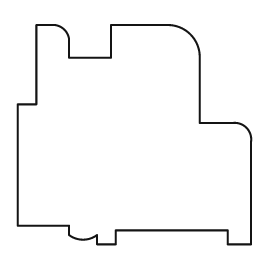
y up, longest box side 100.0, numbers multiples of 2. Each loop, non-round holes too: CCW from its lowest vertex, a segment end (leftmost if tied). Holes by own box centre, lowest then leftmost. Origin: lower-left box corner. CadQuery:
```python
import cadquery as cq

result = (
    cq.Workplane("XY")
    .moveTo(34.0, 0.0)
    .lineTo(42.0, 0.0)
    .lineTo(42.0, 6.0)
    .lineTo(90.0, 6.0)
    .lineTo(90.0, 0.0)
    .lineTo(100.0, 0.0)
    .lineTo(100.0, 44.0)
    .threePointArc((98.0, 50.0), (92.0, 52.0))
    .lineTo(78.0, 52.0)
    .lineTo(78.0, 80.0)
    .threePointArc((74.0, 90.0), (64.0, 94.0))
    .lineTo(40.0, 94.0)
    .lineTo(40.0, 80.0)
    .lineTo(22.0, 80.0)
    .lineTo(22.0, 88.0)
    .threePointArc((20.0, 92.0), (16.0, 94.0))
    .lineTo(8.0, 94.0)
    .lineTo(8.0, 60.0)
    .lineTo(0.0, 60.0)
    .lineTo(0.0, 8.0)
    .lineTo(22.0, 8.0)
    .lineTo(22.0, 4.0)
    .threePointArc((28.0, 2.0), (34.0, 4.0))
    .close()
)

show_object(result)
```